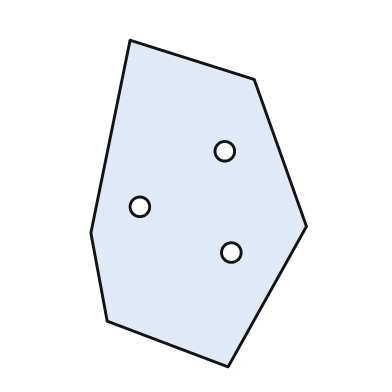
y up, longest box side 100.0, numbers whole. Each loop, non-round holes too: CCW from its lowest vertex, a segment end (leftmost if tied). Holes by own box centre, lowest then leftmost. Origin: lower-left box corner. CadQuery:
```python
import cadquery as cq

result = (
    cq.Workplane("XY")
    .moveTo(42.0, 0.0)
    .lineTo(66.0, 43.0)
    .lineTo(50.0, 88.0)
    .lineTo(12.0, 100.0)
    .lineTo(0.0, 41.0)
    .lineTo(5.0, 14.0)
    .close()
    .moveTo(43.0, 35.0)
    .circle(3.0)
    .moveTo(15.0, 49.0)
    .circle(3.0)
    .moveTo(41.0, 66.0)
    .circle(3.0)
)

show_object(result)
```